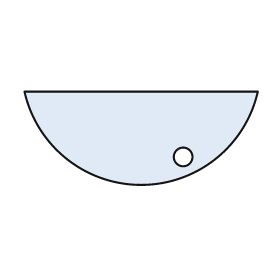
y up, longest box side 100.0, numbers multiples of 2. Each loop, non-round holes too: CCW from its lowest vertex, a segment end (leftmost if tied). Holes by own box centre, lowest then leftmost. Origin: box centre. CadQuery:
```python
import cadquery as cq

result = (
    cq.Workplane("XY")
    .moveTo(-50.0, 20.0)
    .threePointArc((0.0, -20.0), (50.0, 20.0))
    .close()
    .moveTo(18.0, -8.0)
    .circle(4.0)
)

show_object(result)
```